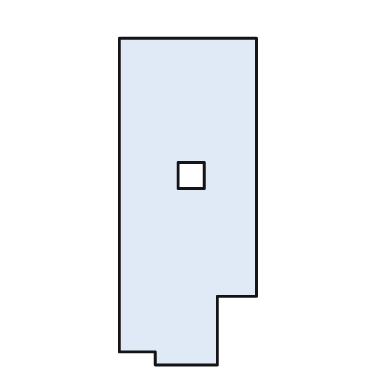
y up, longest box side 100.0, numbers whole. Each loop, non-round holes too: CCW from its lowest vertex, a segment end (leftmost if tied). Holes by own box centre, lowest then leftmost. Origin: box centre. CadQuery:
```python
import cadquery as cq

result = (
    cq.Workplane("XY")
    .moveTo(-10.0, -50.0)
    .lineTo(9.0, -50.0)
    .lineTo(9.0, -29.0)
    .lineTo(21.0, -29.0)
    .lineTo(21.0, 50.0)
    .lineTo(-21.0, 50.0)
    .lineTo(-21.0, -46.0)
    .lineTo(-10.0, -46.0)
    .close()
    .moveTo(-3.0, 4.0)
    .lineTo(5.0, 4.0)
    .lineTo(5.0, 12.0)
    .lineTo(-3.0, 12.0)
    .close()
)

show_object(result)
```